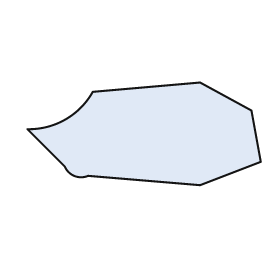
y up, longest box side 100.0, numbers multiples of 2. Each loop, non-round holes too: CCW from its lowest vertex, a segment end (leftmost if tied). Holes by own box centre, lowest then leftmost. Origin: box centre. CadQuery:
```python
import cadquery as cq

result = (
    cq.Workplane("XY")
    .moveTo(24.0, -22.0)
    .lineTo(50.0, -12.0)
    .lineTo(46.0, 10.0)
    .lineTo(24.0, 22.0)
    .lineTo(-22.0, 18.0)
    .threePointArc((-34.0, 6.0), (-50.0, 2.0))
    .lineTo(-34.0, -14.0)
    .threePointArc((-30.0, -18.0), (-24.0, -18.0))
    .close()
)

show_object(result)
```